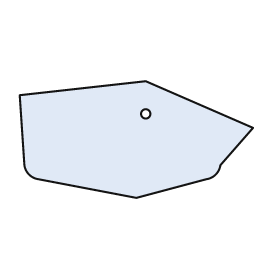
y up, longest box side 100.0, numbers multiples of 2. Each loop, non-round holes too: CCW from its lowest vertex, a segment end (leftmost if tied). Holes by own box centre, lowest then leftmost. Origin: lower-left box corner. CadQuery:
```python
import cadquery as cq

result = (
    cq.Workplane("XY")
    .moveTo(50.0, 0.0)
    .lineTo(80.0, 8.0)
    .threePointArc((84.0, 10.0), (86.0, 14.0))
    .lineTo(100.0, 30.0)
    .lineTo(54.0, 50.0)
    .lineTo(0.0, 44.0)
    .lineTo(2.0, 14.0)
    .threePointArc((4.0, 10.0), (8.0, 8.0))
    .close()
    .moveTo(54.0, 36.0)
    .circle(2.0)
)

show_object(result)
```